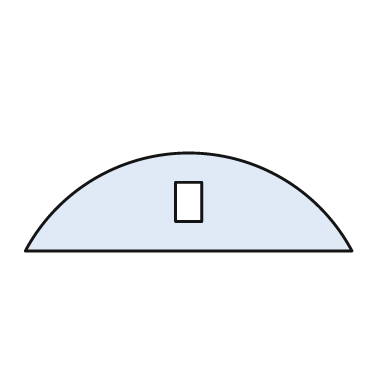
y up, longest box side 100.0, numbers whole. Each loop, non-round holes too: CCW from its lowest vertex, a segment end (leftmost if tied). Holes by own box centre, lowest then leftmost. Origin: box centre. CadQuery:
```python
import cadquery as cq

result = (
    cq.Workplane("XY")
    .moveTo(-50.0, -15.0)
    .lineTo(50.0, -15.0)
    .threePointArc((0.0, 15.0), (-50.0, -15.0))
    .close()
    .moveTo(-4.0, -6.0)
    .lineTo(4.0, -6.0)
    .lineTo(4.0, 6.0)
    .lineTo(-4.0, 6.0)
    .close()
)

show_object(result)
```